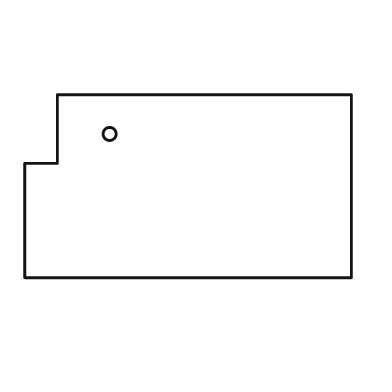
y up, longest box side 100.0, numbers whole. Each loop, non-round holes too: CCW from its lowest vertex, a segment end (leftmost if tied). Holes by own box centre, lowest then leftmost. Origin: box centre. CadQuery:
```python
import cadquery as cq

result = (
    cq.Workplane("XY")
    .moveTo(-50.0, -28.0)
    .lineTo(50.0, -28.0)
    .lineTo(50.0, 28.0)
    .lineTo(-40.0, 28.0)
    .lineTo(-40.0, 7.0)
    .lineTo(-50.0, 7.0)
    .close()
    .moveTo(-24.0, 16.0)
    .circle(2.0)
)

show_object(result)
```